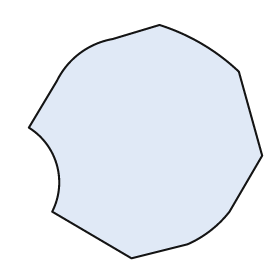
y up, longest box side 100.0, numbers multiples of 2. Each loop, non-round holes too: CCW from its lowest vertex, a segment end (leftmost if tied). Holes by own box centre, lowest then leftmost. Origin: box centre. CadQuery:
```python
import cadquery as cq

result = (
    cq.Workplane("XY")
    .moveTo(-6.0, -50.0)
    .lineTo(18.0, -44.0)
    .threePointArc((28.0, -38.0), (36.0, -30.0))
    .lineTo(50.0, -6.0)
    .lineTo(40.0, 30.0)
    .threePointArc((24.0, 42.0), (6.0, 50.0))
    .lineTo(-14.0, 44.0)
    .threePointArc((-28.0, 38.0), (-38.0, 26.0))
    .lineTo(-50.0, 6.0)
    .threePointArc((-38.0, -10.0), (-40.0, -30.0))
    .close()
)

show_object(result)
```